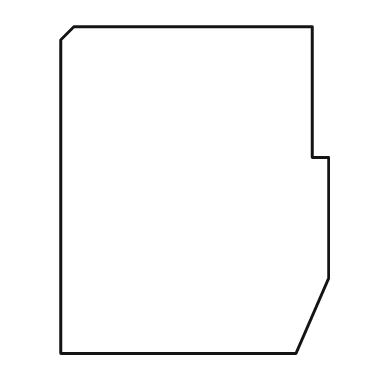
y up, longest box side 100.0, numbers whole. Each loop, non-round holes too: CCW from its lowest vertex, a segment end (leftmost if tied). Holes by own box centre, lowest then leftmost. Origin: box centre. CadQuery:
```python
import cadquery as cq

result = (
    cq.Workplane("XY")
    .moveTo(-41.0, -50.0)
    .lineTo(31.0, -50.0)
    .lineTo(41.0, -27.0)
    .lineTo(41.0, 10.0)
    .lineTo(36.0, 10.0)
    .lineTo(36.0, 50.0)
    .lineTo(-37.0, 50.0)
    .lineTo(-41.0, 46.0)
    .close()
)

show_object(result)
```